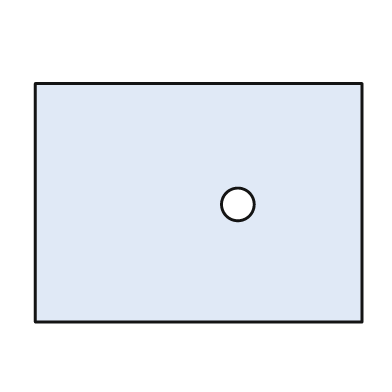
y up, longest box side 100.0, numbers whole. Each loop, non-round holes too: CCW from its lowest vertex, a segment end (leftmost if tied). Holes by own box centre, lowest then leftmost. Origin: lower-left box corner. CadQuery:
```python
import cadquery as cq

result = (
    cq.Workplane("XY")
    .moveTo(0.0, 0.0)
    .lineTo(100.0, 0.0)
    .lineTo(100.0, 73.0)
    .lineTo(0.0, 73.0)
    .close()
    .moveTo(62.0, 36.0)
    .circle(5.0)
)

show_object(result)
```